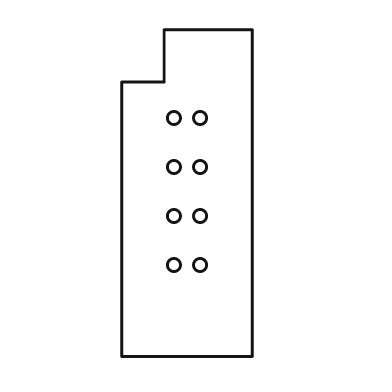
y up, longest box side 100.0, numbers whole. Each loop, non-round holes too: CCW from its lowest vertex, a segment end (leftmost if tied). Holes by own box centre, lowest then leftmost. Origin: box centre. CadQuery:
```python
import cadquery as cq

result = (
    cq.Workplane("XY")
    .moveTo(-20.0, -50.0)
    .lineTo(20.0, -50.0)
    .lineTo(20.0, 50.0)
    .lineTo(-7.0, 50.0)
    .lineTo(-7.0, 34.0)
    .lineTo(-20.0, 34.0)
    .close()
    .moveTo(-4.0, -22.0)
    .circle(2.0)
    .moveTo(4.0, -22.0)
    .circle(2.0)
    .moveTo(-4.0, -7.0)
    .circle(2.0)
    .moveTo(4.0, -7.0)
    .circle(2.0)
    .moveTo(-4.0, 8.0)
    .circle(2.0)
    .moveTo(4.0, 8.0)
    .circle(2.0)
    .moveTo(-4.0, 23.0)
    .circle(2.0)
    .moveTo(4.0, 23.0)
    .circle(2.0)
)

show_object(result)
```